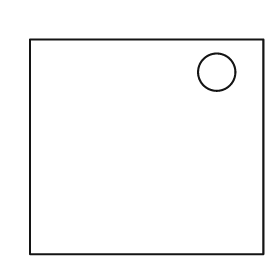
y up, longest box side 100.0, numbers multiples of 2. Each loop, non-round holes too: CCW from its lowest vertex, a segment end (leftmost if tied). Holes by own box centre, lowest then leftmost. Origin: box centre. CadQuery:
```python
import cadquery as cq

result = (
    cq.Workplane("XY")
    .moveTo(-50.0, -46.0)
    .lineTo(50.0, -46.0)
    .lineTo(50.0, 46.0)
    .lineTo(-50.0, 46.0)
    .close()
    .moveTo(30.0, 32.0)
    .circle(8.0)
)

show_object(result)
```